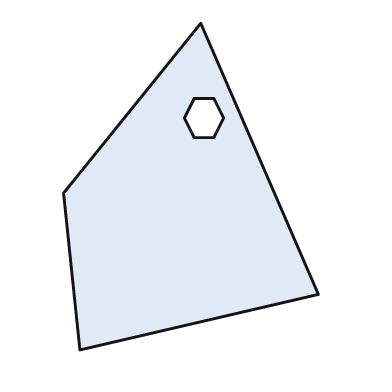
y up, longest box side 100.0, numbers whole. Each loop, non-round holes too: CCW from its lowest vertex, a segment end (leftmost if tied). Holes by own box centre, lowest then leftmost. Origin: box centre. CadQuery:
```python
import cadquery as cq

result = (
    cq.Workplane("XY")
    .moveTo(-34.0, -50.0)
    .lineTo(39.0, -33.0)
    .lineTo(3.0, 50.0)
    .lineTo(-39.0, -2.0)
    .close()
    .moveTo(1.0, 15.0)
    .lineTo(7.0, 15.0)
    .lineTo(10.0, 21.0)
    .lineTo(7.0, 27.0)
    .lineTo(1.0, 27.0)
    .lineTo(-2.0, 21.0)
    .close()
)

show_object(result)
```